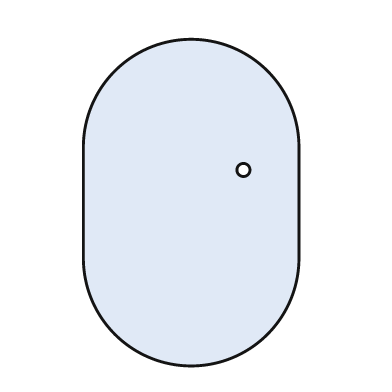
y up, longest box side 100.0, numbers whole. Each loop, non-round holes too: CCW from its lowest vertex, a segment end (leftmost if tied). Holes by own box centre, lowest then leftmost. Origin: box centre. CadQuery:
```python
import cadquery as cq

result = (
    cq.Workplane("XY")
    .moveTo(-33.0, -17.0)
    .threePointArc((0.0, -50.0), (33.0, -17.0))
    .lineTo(33.0, 17.0)
    .threePointArc((0.0, 50.0), (-33.0, 17.0))
    .close()
    .moveTo(16.0, 10.0)
    .circle(2.0)
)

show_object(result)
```